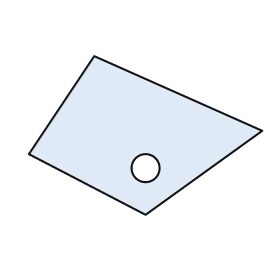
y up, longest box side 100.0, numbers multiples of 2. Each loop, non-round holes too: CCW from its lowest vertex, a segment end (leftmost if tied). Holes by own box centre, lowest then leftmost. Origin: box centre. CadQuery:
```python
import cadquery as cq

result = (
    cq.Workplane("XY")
    .moveTo(0.0, -34.0)
    .lineTo(50.0, 2.0)
    .lineTo(-22.0, 34.0)
    .lineTo(-50.0, -8.0)
    .close()
    .moveTo(0.0, -14.0)
    .circle(6.0)
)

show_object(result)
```